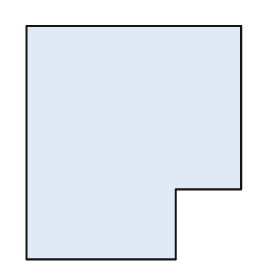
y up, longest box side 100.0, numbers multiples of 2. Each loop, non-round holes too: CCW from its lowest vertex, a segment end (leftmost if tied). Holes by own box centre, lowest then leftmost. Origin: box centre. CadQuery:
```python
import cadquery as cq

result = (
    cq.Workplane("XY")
    .moveTo(-46.0, -50.0)
    .lineTo(18.0, -50.0)
    .lineTo(18.0, -20.0)
    .lineTo(46.0, -20.0)
    .lineTo(46.0, 50.0)
    .lineTo(-46.0, 50.0)
    .close()
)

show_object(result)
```